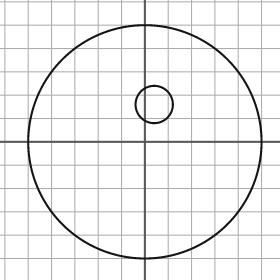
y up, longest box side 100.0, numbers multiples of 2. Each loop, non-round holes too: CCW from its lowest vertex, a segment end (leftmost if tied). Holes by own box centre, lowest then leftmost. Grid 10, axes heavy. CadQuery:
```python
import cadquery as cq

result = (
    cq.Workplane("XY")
    .moveTo(0.0, 0.0)
    .circle(50.0)
    .moveTo(4.0, 16.0)
    .circle(8.0)
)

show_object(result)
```